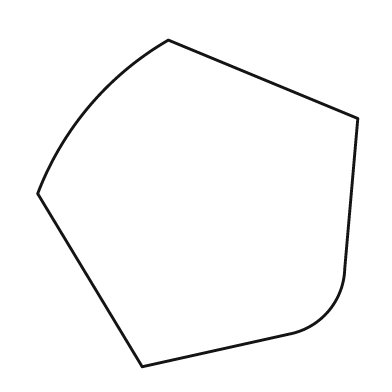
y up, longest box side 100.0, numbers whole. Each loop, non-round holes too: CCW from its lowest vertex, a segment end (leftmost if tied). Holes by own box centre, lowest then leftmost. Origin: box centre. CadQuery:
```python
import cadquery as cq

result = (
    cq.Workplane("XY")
    .moveTo(-17.0, -50.0)
    .lineTo(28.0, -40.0)
    .threePointArc((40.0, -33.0), (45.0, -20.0))
    .lineTo(49.0, 26.0)
    .lineTo(-9.0, 50.0)
    .threePointArc((-33.0, 30.0), (-49.0, 3.0))
    .close()
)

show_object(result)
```